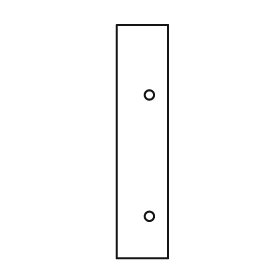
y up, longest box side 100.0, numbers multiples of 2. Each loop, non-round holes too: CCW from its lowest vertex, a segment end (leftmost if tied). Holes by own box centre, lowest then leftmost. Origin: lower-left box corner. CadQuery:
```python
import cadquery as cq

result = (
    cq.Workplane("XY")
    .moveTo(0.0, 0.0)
    .lineTo(22.0, 0.0)
    .lineTo(22.0, 100.0)
    .lineTo(0.0, 100.0)
    .close()
    .moveTo(14.0, 18.0)
    .circle(2.0)
    .moveTo(14.0, 70.0)
    .circle(2.0)
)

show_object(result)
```